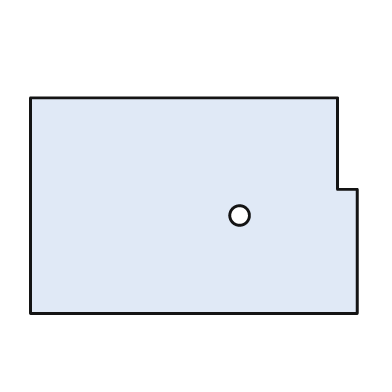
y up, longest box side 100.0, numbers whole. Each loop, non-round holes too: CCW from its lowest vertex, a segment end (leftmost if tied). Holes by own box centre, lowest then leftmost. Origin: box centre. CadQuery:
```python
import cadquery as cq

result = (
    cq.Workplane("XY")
    .moveTo(-50.0, -33.0)
    .lineTo(50.0, -33.0)
    .lineTo(50.0, 5.0)
    .lineTo(44.0, 5.0)
    .lineTo(44.0, 33.0)
    .lineTo(-50.0, 33.0)
    .close()
    .moveTo(14.0, -3.0)
    .circle(3.0)
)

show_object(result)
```